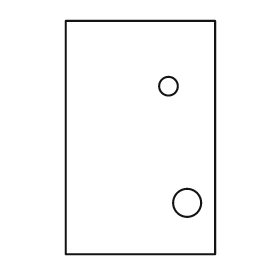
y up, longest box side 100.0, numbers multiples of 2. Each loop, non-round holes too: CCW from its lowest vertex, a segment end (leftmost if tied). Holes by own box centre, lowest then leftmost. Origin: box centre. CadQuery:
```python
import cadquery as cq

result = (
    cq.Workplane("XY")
    .moveTo(-32.0, -50.0)
    .lineTo(32.0, -50.0)
    .lineTo(32.0, 50.0)
    .lineTo(-32.0, 50.0)
    .close()
    .moveTo(20.0, -28.0)
    .circle(6.0)
    .moveTo(12.0, 22.0)
    .circle(4.0)
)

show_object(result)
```